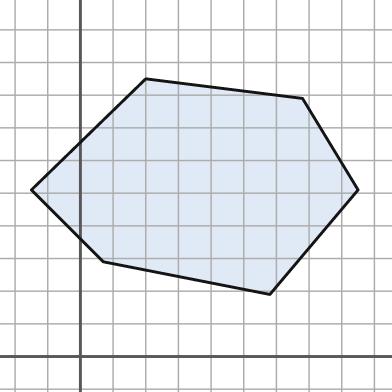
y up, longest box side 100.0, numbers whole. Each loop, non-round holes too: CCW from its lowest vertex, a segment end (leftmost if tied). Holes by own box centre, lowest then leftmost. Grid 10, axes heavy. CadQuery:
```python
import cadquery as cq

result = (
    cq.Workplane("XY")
    .moveTo(58.0, 19.0)
    .lineTo(85.0, 51.0)
    .lineTo(68.0, 79.0)
    .lineTo(20.0, 85.0)
    .lineTo(-15.0, 51.0)
    .lineTo(7.0, 29.0)
    .close()
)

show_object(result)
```